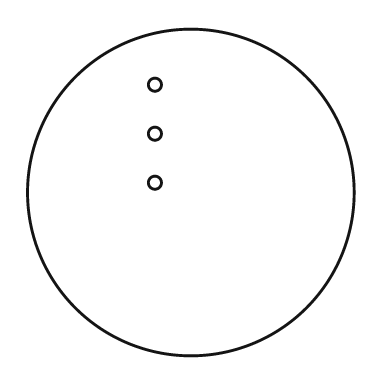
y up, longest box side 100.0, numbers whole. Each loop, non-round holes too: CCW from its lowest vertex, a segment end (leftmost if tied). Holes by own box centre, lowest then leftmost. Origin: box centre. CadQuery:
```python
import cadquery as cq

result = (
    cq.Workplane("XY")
    .moveTo(0.0, 0.0)
    .circle(50.0)
    .moveTo(-11.0, 3.0)
    .circle(2.0)
    .moveTo(-11.0, 18.0)
    .circle(2.0)
    .moveTo(-11.0, 33.0)
    .circle(2.0)
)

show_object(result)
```